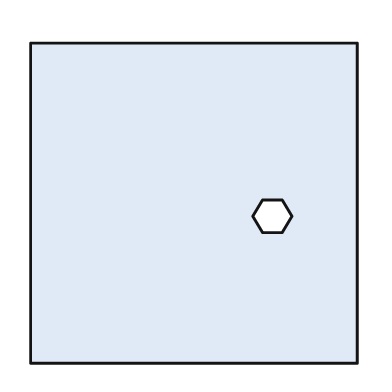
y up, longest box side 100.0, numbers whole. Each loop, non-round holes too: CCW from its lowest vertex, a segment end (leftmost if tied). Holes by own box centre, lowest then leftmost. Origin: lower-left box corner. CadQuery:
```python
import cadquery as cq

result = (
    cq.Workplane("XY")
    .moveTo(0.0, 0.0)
    .lineTo(100.0, 0.0)
    .lineTo(100.0, 98.0)
    .lineTo(0.0, 98.0)
    .close()
    .moveTo(71.0, 40.0)
    .lineTo(77.0, 40.0)
    .lineTo(80.0, 45.0)
    .lineTo(77.0, 50.0)
    .lineTo(71.0, 50.0)
    .lineTo(68.0, 45.0)
    .close()
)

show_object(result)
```